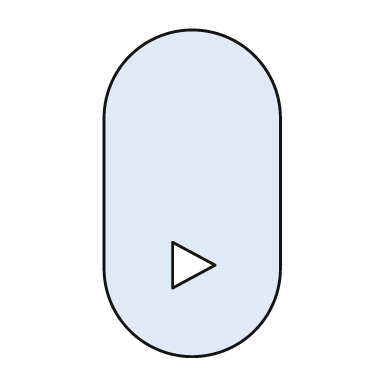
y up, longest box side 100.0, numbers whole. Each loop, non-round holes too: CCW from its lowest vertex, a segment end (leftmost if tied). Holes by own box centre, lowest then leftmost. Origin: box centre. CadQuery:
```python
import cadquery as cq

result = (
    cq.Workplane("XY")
    .moveTo(-27.0, -23.0)
    .threePointArc((0.0, -50.0), (27.0, -23.0))
    .lineTo(27.0, 23.0)
    .threePointArc((0.0, 50.0), (-27.0, 23.0))
    .close()
    .moveTo(-6.0, -29.0)
    .lineTo(7.0, -22.0)
    .lineTo(-6.0, -15.0)
    .close()
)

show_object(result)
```